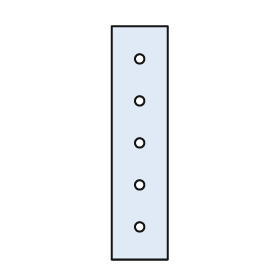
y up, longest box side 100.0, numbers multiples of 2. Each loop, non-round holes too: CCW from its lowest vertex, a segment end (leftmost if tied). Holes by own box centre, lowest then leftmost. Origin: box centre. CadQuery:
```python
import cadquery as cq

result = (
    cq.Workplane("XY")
    .moveTo(-12.0, -50.0)
    .lineTo(12.0, -50.0)
    .lineTo(12.0, 50.0)
    .lineTo(-12.0, 50.0)
    .close()
    .moveTo(0.0, -36.0)
    .circle(2.0)
    .moveTo(0.0, -18.0)
    .circle(2.0)
    .moveTo(0.0, 0.0)
    .circle(2.0)
    .moveTo(0.0, 18.0)
    .circle(2.0)
    .moveTo(0.0, 36.0)
    .circle(2.0)
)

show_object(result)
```